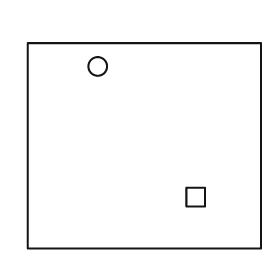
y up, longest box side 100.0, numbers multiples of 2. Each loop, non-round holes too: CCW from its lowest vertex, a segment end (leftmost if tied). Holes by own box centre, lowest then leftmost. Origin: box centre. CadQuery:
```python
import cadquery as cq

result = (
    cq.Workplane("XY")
    .moveTo(-50.0, -44.0)
    .lineTo(50.0, -44.0)
    .lineTo(50.0, 44.0)
    .lineTo(-50.0, 44.0)
    .close()
    .moveTo(18.0, -26.0)
    .lineTo(26.0, -26.0)
    .lineTo(26.0, -18.0)
    .lineTo(18.0, -18.0)
    .close()
    .moveTo(-20.0, 34.0)
    .circle(4.0)
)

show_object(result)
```